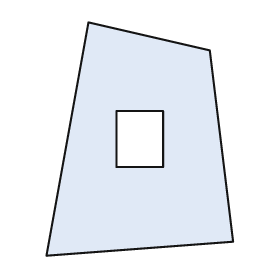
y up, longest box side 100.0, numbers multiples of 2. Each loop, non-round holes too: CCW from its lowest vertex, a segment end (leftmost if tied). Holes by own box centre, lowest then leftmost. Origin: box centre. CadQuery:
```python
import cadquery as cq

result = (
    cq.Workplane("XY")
    .moveTo(-40.0, -50.0)
    .lineTo(40.0, -44.0)
    .lineTo(30.0, 38.0)
    .lineTo(-22.0, 50.0)
    .close()
    .moveTo(-10.0, -12.0)
    .lineTo(10.0, -12.0)
    .lineTo(10.0, 12.0)
    .lineTo(-10.0, 12.0)
    .close()
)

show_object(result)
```